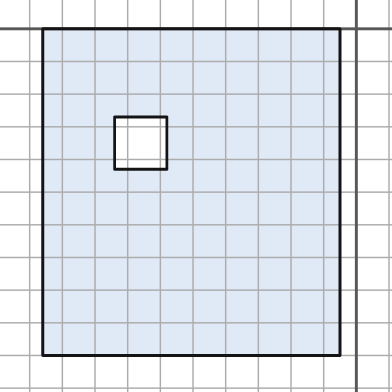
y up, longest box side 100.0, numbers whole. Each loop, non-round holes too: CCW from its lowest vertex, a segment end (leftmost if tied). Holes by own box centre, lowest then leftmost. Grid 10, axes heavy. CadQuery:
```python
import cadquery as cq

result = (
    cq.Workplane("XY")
    .moveTo(-96.0, -100.0)
    .lineTo(-5.0, -100.0)
    .lineTo(-5.0, 0.0)
    .lineTo(-96.0, 0.0)
    .close()
    .moveTo(-74.0, -43.0)
    .lineTo(-58.0, -43.0)
    .lineTo(-58.0, -27.0)
    .lineTo(-74.0, -27.0)
    .close()
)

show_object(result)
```